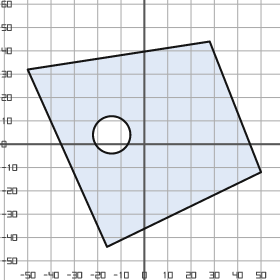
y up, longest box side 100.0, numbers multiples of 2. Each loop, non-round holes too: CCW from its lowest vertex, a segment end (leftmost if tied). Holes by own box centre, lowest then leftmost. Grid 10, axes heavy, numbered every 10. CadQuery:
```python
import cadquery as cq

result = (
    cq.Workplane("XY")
    .moveTo(-16.0, -44.0)
    .lineTo(50.0, -12.0)
    .lineTo(28.0, 44.0)
    .lineTo(-50.0, 32.0)
    .close()
    .moveTo(-14.0, 4.0)
    .circle(8.0)
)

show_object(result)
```